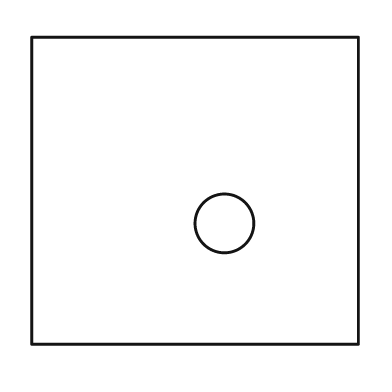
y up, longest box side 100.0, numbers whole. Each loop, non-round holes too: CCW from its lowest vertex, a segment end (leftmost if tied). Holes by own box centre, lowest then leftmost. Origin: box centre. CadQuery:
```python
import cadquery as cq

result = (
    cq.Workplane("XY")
    .moveTo(-50.0, -47.0)
    .lineTo(50.0, -47.0)
    .lineTo(50.0, 47.0)
    .lineTo(-50.0, 47.0)
    .close()
    .moveTo(9.0, -10.0)
    .circle(9.0)
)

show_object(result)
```